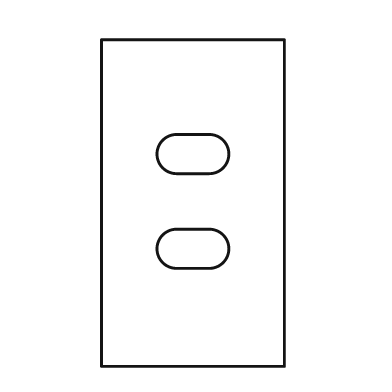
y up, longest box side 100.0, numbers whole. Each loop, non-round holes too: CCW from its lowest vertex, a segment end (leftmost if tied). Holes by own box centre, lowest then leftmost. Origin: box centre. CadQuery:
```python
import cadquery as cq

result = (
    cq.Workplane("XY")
    .moveTo(-28.0, -50.0)
    .lineTo(28.0, -50.0)
    .lineTo(28.0, 50.0)
    .lineTo(-28.0, 50.0)
    .close()
    .moveTo(-5.0, -20.0)
    .lineTo(5.0, -20.0)
    .threePointArc((11.0, -14.0), (5.0, -8.0))
    .lineTo(-5.0, -8.0)
    .threePointArc((-11.0, -14.0), (-5.0, -20.0))
    .close()
    .moveTo(-5.0, 9.0)
    .lineTo(5.0, 9.0)
    .threePointArc((11.0, 15.0), (5.0, 21.0))
    .lineTo(-5.0, 21.0)
    .threePointArc((-11.0, 15.0), (-5.0, 9.0))
    .close()
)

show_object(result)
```